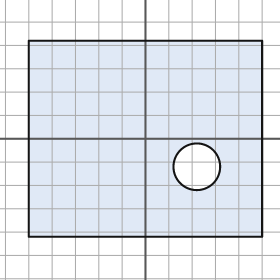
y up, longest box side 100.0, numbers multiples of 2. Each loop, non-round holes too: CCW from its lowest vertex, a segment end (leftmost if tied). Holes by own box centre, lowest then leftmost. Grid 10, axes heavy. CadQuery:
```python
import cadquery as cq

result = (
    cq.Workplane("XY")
    .moveTo(-50.0, -42.0)
    .lineTo(50.0, -42.0)
    .lineTo(50.0, 42.0)
    .lineTo(-50.0, 42.0)
    .close()
    .moveTo(22.0, -12.0)
    .circle(10.0)
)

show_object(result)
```